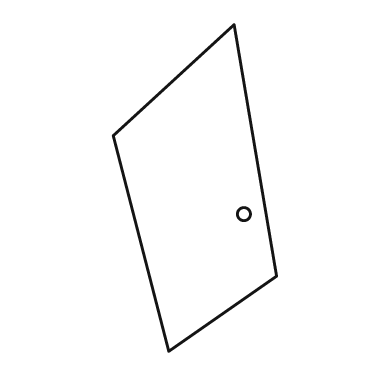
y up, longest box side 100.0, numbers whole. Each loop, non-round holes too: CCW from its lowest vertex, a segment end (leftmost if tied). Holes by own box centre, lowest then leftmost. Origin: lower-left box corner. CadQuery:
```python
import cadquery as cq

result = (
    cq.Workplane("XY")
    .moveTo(17.0, 0.0)
    .lineTo(50.0, 23.0)
    .lineTo(37.0, 100.0)
    .lineTo(0.0, 66.0)
    .close()
    .moveTo(40.0, 42.0)
    .circle(2.0)
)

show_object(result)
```